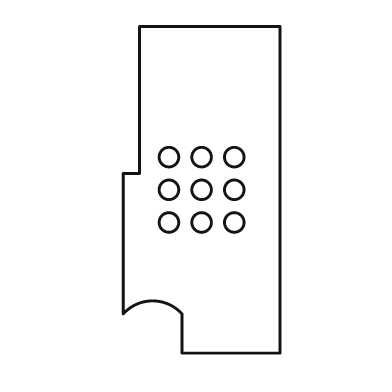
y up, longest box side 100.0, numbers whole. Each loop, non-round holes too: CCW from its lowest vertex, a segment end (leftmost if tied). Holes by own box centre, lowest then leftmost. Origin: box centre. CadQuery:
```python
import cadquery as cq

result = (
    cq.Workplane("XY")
    .moveTo(-6.0, -50.0)
    .lineTo(24.0, -50.0)
    .lineTo(24.0, 50.0)
    .lineTo(-19.0, 50.0)
    .lineTo(-19.0, 5.0)
    .lineTo(-24.0, 5.0)
    .lineTo(-24.0, -38.0)
    .threePointArc((-15.0, -34.0), (-6.0, -38.0))
    .close()
    .moveTo(-10.0, -10.0)
    .circle(3.0)
    .moveTo(0.0, -10.0)
    .circle(3.0)
    .moveTo(10.0, -10.0)
    .circle(3.0)
    .moveTo(-10.0, 0.0)
    .circle(3.0)
    .moveTo(0.0, 0.0)
    .circle(3.0)
    .moveTo(10.0, 0.0)
    .circle(3.0)
    .moveTo(-10.0, 10.0)
    .circle(3.0)
    .moveTo(0.0, 10.0)
    .circle(3.0)
    .moveTo(10.0, 10.0)
    .circle(3.0)
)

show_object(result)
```